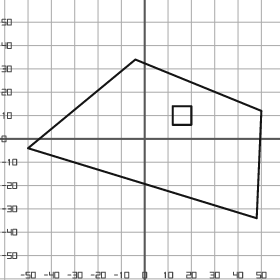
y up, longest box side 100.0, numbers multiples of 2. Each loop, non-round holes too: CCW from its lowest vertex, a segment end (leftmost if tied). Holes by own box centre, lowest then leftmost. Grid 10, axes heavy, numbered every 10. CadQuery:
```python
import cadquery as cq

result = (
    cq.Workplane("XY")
    .moveTo(48.0, -34.0)
    .lineTo(50.0, 12.0)
    .lineTo(-4.0, 34.0)
    .lineTo(-50.0, -4.0)
    .close()
    .moveTo(12.0, 6.0)
    .lineTo(20.0, 6.0)
    .lineTo(20.0, 14.0)
    .lineTo(12.0, 14.0)
    .close()
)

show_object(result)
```